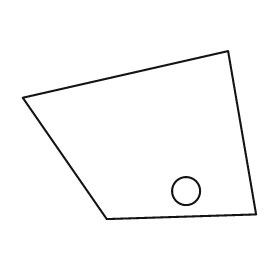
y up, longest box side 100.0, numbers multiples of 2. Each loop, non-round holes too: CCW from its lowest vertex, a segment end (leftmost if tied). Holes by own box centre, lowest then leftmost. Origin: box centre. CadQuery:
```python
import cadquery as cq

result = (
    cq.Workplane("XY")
    .moveTo(-14.0, -36.0)
    .lineTo(50.0, -34.0)
    .lineTo(38.0, 36.0)
    .lineTo(-50.0, 16.0)
    .close()
    .moveTo(20.0, -24.0)
    .circle(6.0)
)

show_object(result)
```